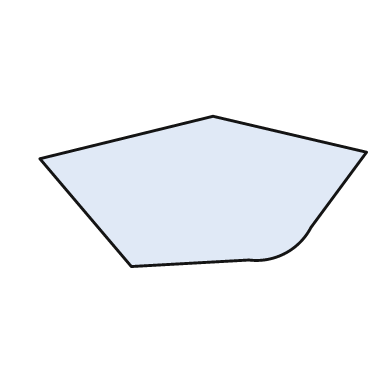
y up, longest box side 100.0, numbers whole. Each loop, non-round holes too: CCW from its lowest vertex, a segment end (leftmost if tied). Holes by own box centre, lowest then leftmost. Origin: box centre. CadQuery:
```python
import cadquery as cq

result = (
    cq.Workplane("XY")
    .moveTo(-22.0, -23.0)
    .lineTo(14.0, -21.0)
    .threePointArc((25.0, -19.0), (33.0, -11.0))
    .lineTo(50.0, 12.0)
    .lineTo(3.0, 23.0)
    .lineTo(-50.0, 10.0)
    .close()
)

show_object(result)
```